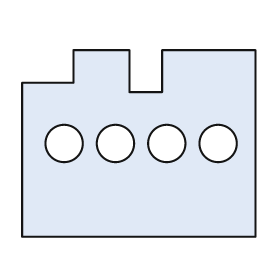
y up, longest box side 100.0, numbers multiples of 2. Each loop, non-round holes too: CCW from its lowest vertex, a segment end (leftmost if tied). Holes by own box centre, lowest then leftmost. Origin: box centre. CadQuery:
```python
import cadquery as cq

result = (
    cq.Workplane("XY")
    .moveTo(-50.0, -40.0)
    .lineTo(50.0, -40.0)
    .lineTo(50.0, 40.0)
    .lineTo(10.0, 40.0)
    .lineTo(10.0, 22.0)
    .lineTo(-4.0, 22.0)
    .lineTo(-4.0, 40.0)
    .lineTo(-28.0, 40.0)
    .lineTo(-28.0, 26.0)
    .lineTo(-50.0, 26.0)
    .close()
    .moveTo(-32.0, 0.0)
    .circle(8.0)
    .moveTo(-10.0, 0.0)
    .circle(8.0)
    .moveTo(12.0, 0.0)
    .circle(8.0)
    .moveTo(34.0, 0.0)
    .circle(8.0)
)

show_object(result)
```